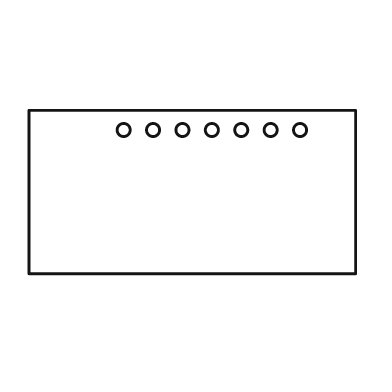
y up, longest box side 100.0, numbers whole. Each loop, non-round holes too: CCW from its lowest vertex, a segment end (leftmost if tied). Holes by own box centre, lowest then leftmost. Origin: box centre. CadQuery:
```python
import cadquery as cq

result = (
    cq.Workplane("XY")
    .moveTo(-50.0, -25.0)
    .lineTo(50.0, -25.0)
    .lineTo(50.0, 25.0)
    .lineTo(-50.0, 25.0)
    .close()
    .moveTo(-21.0, 19.0)
    .circle(2.0)
    .moveTo(-12.0, 19.0)
    .circle(2.0)
    .moveTo(-3.0, 19.0)
    .circle(2.0)
    .moveTo(6.0, 19.0)
    .circle(2.0)
    .moveTo(15.0, 19.0)
    .circle(2.0)
    .moveTo(24.0, 19.0)
    .circle(2.0)
    .moveTo(33.0, 19.0)
    .circle(2.0)
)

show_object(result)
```